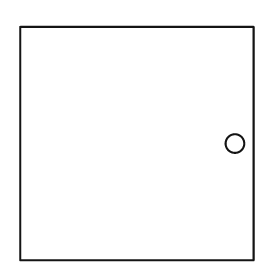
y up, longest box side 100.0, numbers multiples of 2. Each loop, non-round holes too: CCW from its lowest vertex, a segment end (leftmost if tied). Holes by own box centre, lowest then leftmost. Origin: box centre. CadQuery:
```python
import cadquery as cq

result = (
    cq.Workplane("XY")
    .moveTo(-50.0, -50.0)
    .lineTo(50.0, -50.0)
    .lineTo(50.0, 50.0)
    .lineTo(-50.0, 50.0)
    .close()
    .moveTo(42.0, 0.0)
    .circle(4.0)
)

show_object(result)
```